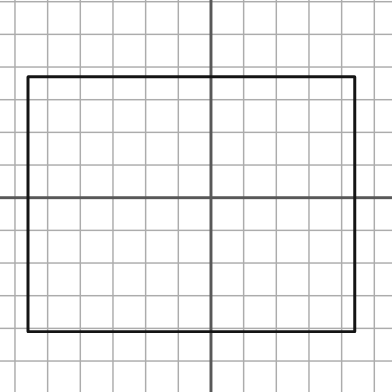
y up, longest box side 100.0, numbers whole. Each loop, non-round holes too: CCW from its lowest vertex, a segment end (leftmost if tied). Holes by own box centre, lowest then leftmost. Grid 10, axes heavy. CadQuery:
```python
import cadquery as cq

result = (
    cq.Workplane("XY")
    .moveTo(-56.0, -41.0)
    .lineTo(44.0, -41.0)
    .lineTo(44.0, 37.0)
    .lineTo(-56.0, 37.0)
    .close()
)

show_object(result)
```